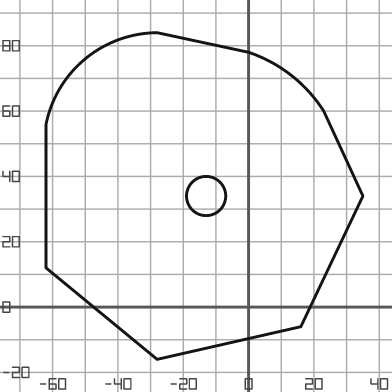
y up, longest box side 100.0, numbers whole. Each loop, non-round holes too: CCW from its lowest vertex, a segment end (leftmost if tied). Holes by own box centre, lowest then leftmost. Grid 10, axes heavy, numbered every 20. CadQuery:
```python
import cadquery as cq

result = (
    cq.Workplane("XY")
    .moveTo(-28.0, -16.0)
    .lineTo(16.0, -6.0)
    .lineTo(35.0, 34.0)
    .lineTo(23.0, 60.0)
    .threePointArc((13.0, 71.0), (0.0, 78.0))
    .lineTo(-28.0, 84.0)
    .threePointArc((-50.0, 76.0), (-62.0, 56.0))
    .lineTo(-62.0, 12.0)
    .close()
    .moveTo(-13.0, 34.0)
    .circle(6.0)
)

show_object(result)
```